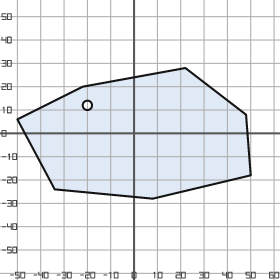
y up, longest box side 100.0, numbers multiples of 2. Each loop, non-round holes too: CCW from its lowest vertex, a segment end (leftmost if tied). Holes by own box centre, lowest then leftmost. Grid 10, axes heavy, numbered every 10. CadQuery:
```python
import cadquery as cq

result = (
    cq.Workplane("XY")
    .moveTo(8.0, -28.0)
    .lineTo(50.0, -18.0)
    .lineTo(48.0, 8.0)
    .lineTo(22.0, 28.0)
    .lineTo(-22.0, 20.0)
    .lineTo(-50.0, 6.0)
    .lineTo(-34.0, -24.0)
    .close()
    .moveTo(-20.0, 12.0)
    .circle(2.0)
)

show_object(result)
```